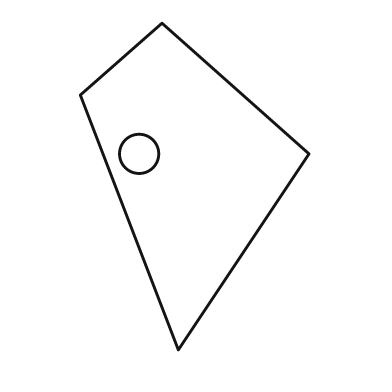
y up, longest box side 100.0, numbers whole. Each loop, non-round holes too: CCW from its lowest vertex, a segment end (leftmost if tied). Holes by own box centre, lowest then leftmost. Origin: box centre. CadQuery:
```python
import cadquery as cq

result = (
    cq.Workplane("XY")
    .moveTo(-5.0, -50.0)
    .lineTo(35.0, 10.0)
    .lineTo(-10.0, 50.0)
    .lineTo(-35.0, 28.0)
    .close()
    .moveTo(-17.0, 10.0)
    .circle(6.0)
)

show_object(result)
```